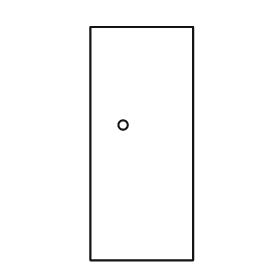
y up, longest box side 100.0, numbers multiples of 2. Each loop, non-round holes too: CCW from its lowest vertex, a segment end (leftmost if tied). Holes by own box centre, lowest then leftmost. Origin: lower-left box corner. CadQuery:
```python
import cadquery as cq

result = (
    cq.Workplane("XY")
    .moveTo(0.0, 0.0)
    .lineTo(44.0, 0.0)
    .lineTo(44.0, 100.0)
    .lineTo(0.0, 100.0)
    .close()
    .moveTo(14.0, 58.0)
    .circle(2.0)
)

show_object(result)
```